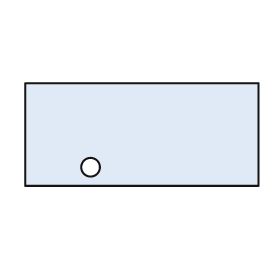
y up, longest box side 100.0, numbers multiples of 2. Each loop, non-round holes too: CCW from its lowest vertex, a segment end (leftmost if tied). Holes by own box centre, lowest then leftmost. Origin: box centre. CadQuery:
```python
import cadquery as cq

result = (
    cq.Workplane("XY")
    .moveTo(-50.0, -22.0)
    .lineTo(50.0, -22.0)
    .lineTo(50.0, 22.0)
    .lineTo(-50.0, 22.0)
    .close()
    .moveTo(-22.0, -14.0)
    .circle(4.0)
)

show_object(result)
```